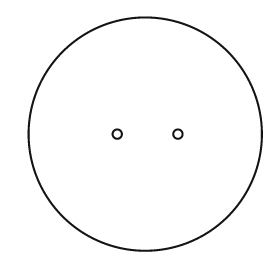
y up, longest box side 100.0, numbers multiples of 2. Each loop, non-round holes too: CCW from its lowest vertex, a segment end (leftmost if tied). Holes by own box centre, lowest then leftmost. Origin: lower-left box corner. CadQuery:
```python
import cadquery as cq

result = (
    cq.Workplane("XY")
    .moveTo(50.0, 50.0)
    .circle(50.0)
    .moveTo(38.0, 50.0)
    .circle(2.0)
    .moveTo(64.0, 50.0)
    .circle(2.0)
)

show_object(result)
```